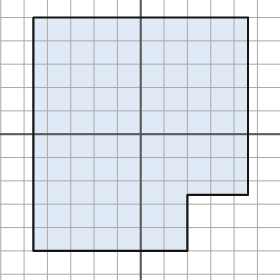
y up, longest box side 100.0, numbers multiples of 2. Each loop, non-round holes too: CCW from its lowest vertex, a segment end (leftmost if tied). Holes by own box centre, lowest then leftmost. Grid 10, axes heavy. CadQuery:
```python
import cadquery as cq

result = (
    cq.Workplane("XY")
    .moveTo(-46.0, -50.0)
    .lineTo(20.0, -50.0)
    .lineTo(20.0, -26.0)
    .lineTo(46.0, -26.0)
    .lineTo(46.0, 50.0)
    .lineTo(-46.0, 50.0)
    .close()
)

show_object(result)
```